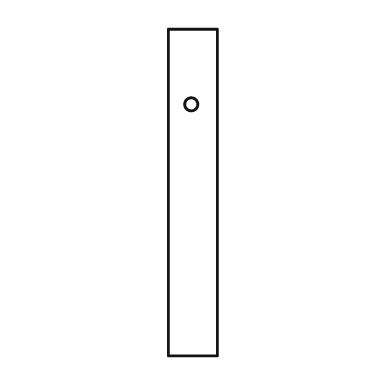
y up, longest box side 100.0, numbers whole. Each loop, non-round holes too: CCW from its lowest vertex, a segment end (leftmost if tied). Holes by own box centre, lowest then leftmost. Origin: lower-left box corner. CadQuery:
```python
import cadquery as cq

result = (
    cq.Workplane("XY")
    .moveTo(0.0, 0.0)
    .lineTo(15.0, 0.0)
    .lineTo(15.0, 100.0)
    .lineTo(0.0, 100.0)
    .close()
    .moveTo(7.0, 77.0)
    .circle(2.0)
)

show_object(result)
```